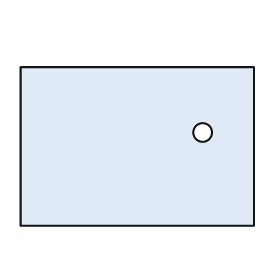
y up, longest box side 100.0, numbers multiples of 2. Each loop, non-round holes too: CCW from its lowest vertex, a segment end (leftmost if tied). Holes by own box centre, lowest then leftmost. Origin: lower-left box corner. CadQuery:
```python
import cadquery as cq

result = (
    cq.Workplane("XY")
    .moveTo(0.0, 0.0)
    .lineTo(100.0, 0.0)
    .lineTo(100.0, 68.0)
    .lineTo(0.0, 68.0)
    .close()
    .moveTo(78.0, 40.0)
    .circle(4.0)
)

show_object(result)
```